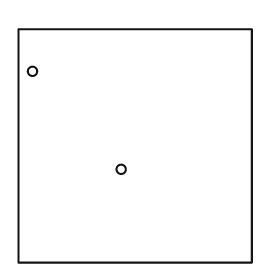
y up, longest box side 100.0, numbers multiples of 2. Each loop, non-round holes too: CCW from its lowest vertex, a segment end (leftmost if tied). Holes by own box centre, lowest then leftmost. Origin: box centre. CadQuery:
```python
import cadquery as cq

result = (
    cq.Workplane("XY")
    .moveTo(-50.0, -50.0)
    .lineTo(50.0, -50.0)
    .lineTo(50.0, 50.0)
    .lineTo(-50.0, 50.0)
    .close()
    .moveTo(-6.0, -10.0)
    .circle(2.0)
    .moveTo(-44.0, 32.0)
    .circle(2.0)
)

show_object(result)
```